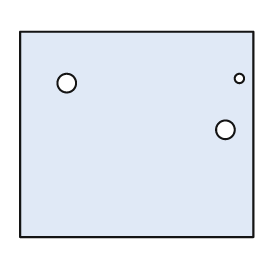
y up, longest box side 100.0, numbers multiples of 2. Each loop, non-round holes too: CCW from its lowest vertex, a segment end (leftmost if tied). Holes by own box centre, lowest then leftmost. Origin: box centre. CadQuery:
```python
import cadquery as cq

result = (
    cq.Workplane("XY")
    .moveTo(-50.0, -44.0)
    .lineTo(50.0, -44.0)
    .lineTo(50.0, 44.0)
    .lineTo(-50.0, 44.0)
    .close()
    .moveTo(38.0, 2.0)
    .circle(4.0)
    .moveTo(-30.0, 22.0)
    .circle(4.0)
    .moveTo(44.0, 24.0)
    .circle(2.0)
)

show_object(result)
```